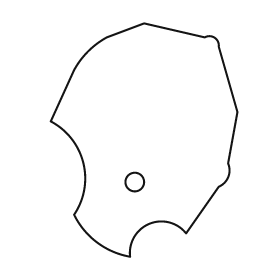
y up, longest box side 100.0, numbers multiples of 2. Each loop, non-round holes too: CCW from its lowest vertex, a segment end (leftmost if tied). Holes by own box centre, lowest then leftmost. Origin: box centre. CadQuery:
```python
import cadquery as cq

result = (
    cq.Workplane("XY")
    .moveTo(-6.0, -50.0)
    .threePointArc((2.0, -36.0), (18.0, -40.0))
    .lineTo(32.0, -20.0)
    .threePointArc((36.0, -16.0), (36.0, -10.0))
    .lineTo(40.0, 12.0)
    .lineTo(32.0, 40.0)
    .threePointArc((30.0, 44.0), (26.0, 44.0))
    .lineTo(0.0, 50.0)
    .lineTo(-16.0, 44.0)
    .threePointArc((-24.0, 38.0), (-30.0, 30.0))
    .lineTo(-40.0, 8.0)
    .threePointArc((-26.0, -10.0), (-30.0, -32.0))
    .threePointArc((-20.0, -44.0), (-6.0, -50.0))
    .close()
    .moveTo(-4.0, -18.0)
    .circle(4.0)
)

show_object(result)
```